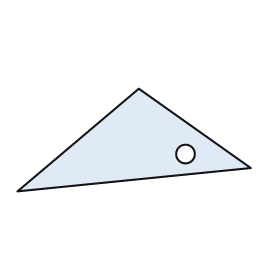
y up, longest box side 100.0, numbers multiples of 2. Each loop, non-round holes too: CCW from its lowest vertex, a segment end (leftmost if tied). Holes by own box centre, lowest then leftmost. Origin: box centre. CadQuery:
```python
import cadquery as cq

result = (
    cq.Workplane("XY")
    .moveTo(-50.0, -22.0)
    .lineTo(50.0, -12.0)
    .lineTo(2.0, 22.0)
    .close()
    .moveTo(22.0, -6.0)
    .circle(4.0)
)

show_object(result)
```